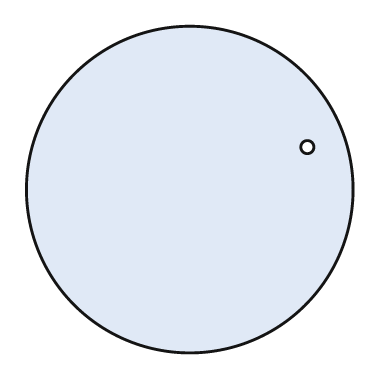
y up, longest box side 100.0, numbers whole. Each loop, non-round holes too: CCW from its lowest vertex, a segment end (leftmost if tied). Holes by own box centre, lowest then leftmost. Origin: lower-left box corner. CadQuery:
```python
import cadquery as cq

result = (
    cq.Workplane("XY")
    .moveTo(50.0, 50.0)
    .circle(50.0)
    .moveTo(86.0, 63.0)
    .circle(2.0)
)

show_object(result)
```